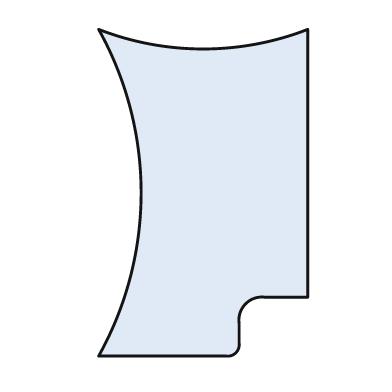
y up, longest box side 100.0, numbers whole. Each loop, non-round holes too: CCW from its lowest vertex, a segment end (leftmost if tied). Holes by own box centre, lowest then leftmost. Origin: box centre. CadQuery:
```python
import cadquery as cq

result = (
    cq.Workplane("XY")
    .moveTo(-32.0, -50.0)
    .lineTo(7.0, -50.0)
    .threePointArc((10.0, -49.0), (11.0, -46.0))
    .lineTo(11.0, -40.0)
    .threePointArc((13.0, -34.0), (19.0, -32.0))
    .lineTo(32.0, -32.0)
    .lineTo(32.0, 50.0)
    .threePointArc((0.0, 44.0), (-32.0, 50.0))
    .threePointArc((-19.0, 0.0), (-32.0, -50.0))
    .close()
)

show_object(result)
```